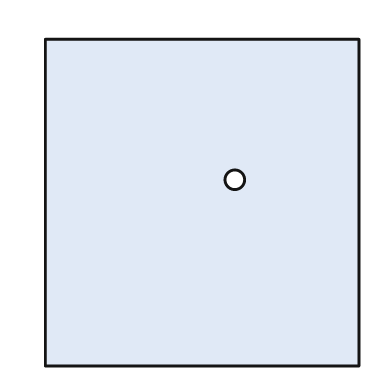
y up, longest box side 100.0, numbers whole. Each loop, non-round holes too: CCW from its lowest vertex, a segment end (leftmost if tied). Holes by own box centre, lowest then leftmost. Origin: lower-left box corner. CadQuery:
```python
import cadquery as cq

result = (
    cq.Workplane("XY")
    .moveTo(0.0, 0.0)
    .lineTo(96.0, 0.0)
    .lineTo(96.0, 100.0)
    .lineTo(0.0, 100.0)
    .close()
    .moveTo(58.0, 57.0)
    .circle(3.0)
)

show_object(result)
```